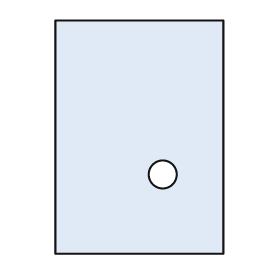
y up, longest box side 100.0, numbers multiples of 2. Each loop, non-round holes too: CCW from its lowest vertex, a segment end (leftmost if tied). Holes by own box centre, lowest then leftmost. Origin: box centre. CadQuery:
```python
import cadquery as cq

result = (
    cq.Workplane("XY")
    .moveTo(-36.0, -50.0)
    .lineTo(36.0, -50.0)
    .lineTo(36.0, 50.0)
    .lineTo(-36.0, 50.0)
    .close()
    .moveTo(10.0, -16.0)
    .circle(6.0)
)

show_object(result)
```